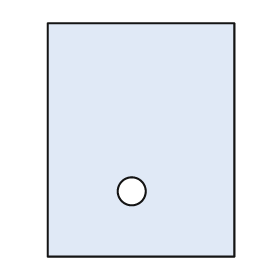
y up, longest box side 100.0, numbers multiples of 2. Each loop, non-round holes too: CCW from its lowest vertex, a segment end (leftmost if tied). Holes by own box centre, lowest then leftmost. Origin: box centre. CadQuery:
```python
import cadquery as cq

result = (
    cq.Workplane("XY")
    .moveTo(-40.0, -50.0)
    .lineTo(40.0, -50.0)
    .lineTo(40.0, 50.0)
    .lineTo(-40.0, 50.0)
    .close()
    .moveTo(-4.0, -22.0)
    .circle(6.0)
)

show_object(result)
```